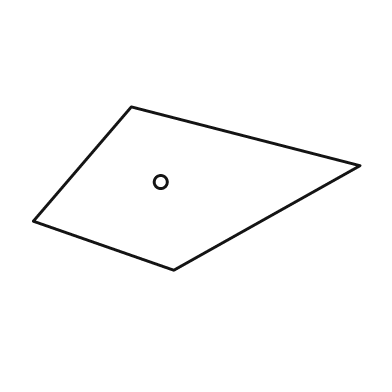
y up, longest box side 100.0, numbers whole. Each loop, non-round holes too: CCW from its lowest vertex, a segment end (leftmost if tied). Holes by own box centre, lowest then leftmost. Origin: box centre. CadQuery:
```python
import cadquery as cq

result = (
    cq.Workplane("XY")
    .moveTo(-7.0, -25.0)
    .lineTo(50.0, 7.0)
    .lineTo(-20.0, 25.0)
    .lineTo(-50.0, -10.0)
    .close()
    .moveTo(-11.0, 2.0)
    .circle(2.0)
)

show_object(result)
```